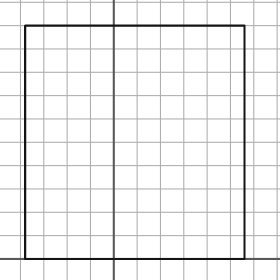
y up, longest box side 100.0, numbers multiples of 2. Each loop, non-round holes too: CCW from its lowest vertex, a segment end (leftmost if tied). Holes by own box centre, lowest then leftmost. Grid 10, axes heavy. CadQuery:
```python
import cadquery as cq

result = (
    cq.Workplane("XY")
    .moveTo(-38.0, 0.0)
    .lineTo(56.0, 0.0)
    .lineTo(56.0, 100.0)
    .lineTo(-38.0, 100.0)
    .close()
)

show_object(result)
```